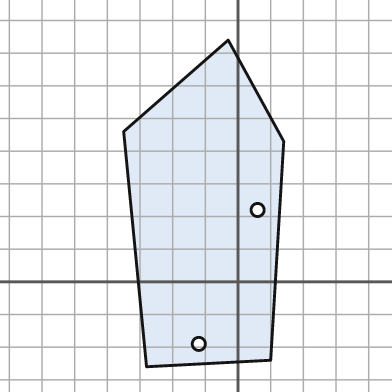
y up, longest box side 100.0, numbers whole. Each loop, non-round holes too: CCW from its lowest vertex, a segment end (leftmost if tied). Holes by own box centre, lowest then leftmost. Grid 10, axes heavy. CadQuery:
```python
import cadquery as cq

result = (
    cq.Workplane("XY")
    .moveTo(-28.0, -26.0)
    .lineTo(10.0, -24.0)
    .lineTo(14.0, 43.0)
    .lineTo(-3.0, 74.0)
    .lineTo(-35.0, 46.0)
    .close()
    .moveTo(-12.0, -19.0)
    .circle(2.0)
    .moveTo(6.0, 22.0)
    .circle(2.0)
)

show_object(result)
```